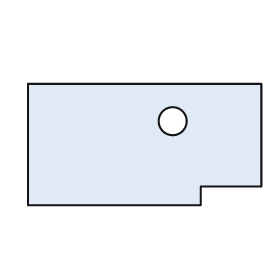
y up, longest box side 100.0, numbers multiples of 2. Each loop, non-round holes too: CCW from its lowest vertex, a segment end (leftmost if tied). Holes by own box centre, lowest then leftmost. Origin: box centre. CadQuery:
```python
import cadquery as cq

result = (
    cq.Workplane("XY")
    .moveTo(-50.0, -26.0)
    .lineTo(24.0, -26.0)
    .lineTo(24.0, -18.0)
    .lineTo(50.0, -18.0)
    .lineTo(50.0, 26.0)
    .lineTo(-50.0, 26.0)
    .close()
    .moveTo(12.0, 10.0)
    .circle(6.0)
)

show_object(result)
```